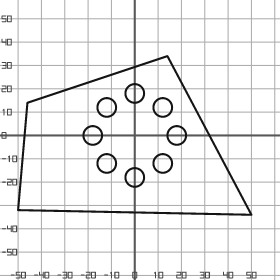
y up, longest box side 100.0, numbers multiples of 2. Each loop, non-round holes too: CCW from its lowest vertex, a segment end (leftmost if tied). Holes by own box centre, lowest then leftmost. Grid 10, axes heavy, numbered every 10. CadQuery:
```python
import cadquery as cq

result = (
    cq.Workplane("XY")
    .moveTo(50.0, -34.0)
    .lineTo(14.0, 34.0)
    .lineTo(-46.0, 14.0)
    .lineTo(-50.0, -32.0)
    .close()
    .moveTo(0.0, -18.0)
    .circle(4.0)
    .moveTo(-12.0, -12.0)
    .circle(4.0)
    .moveTo(12.0, -12.0)
    .circle(4.0)
    .moveTo(-18.0, 0.0)
    .circle(4.0)
    .moveTo(18.0, 0.0)
    .circle(4.0)
    .moveTo(-12.0, 12.0)
    .circle(4.0)
    .moveTo(12.0, 12.0)
    .circle(4.0)
    .moveTo(0.0, 18.0)
    .circle(4.0)
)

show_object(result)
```